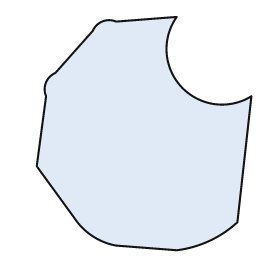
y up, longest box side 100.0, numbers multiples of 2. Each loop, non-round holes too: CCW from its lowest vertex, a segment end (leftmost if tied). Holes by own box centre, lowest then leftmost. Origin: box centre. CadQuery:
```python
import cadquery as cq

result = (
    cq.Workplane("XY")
    .moveTo(14.0, -50.0)
    .threePointArc((28.0, -46.0), (40.0, -38.0))
    .lineTo(46.0, 16.0)
    .threePointArc((16.0, 20.0), (14.0, 50.0))
    .lineTo(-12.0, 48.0)
    .threePointArc((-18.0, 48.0), (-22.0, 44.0))
    .lineTo(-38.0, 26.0)
    .threePointArc((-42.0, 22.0), (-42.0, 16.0))
    .lineTo(-46.0, -14.0)
    .lineTo(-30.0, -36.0)
    .threePointArc((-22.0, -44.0), (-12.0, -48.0))
    .close()
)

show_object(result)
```